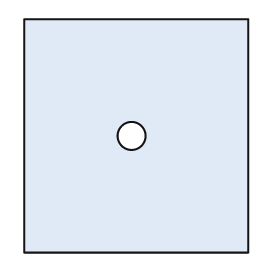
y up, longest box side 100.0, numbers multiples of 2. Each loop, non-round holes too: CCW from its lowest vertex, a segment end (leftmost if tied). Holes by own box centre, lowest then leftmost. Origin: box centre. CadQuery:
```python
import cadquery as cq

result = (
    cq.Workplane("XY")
    .moveTo(-48.0, -50.0)
    .lineTo(48.0, -50.0)
    .lineTo(48.0, 50.0)
    .lineTo(-48.0, 50.0)
    .close()
    .moveTo(-2.0, 0.0)
    .circle(6.0)
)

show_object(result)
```